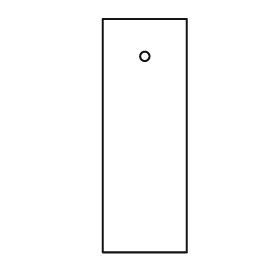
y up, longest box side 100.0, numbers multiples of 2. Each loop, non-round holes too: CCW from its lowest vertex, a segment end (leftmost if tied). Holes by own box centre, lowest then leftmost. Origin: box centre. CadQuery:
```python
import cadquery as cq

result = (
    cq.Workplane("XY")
    .moveTo(-18.0, -50.0)
    .lineTo(18.0, -50.0)
    .lineTo(18.0, 50.0)
    .lineTo(-18.0, 50.0)
    .close()
    .moveTo(0.0, 34.0)
    .circle(2.0)
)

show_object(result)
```